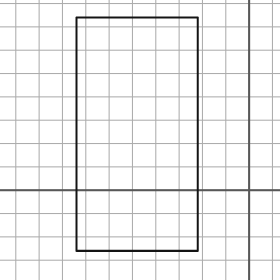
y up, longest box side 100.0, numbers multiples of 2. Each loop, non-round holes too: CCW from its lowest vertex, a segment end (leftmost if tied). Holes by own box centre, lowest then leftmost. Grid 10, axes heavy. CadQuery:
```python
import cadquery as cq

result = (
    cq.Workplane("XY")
    .moveTo(-74.0, -26.0)
    .lineTo(-22.0, -26.0)
    .lineTo(-22.0, 74.0)
    .lineTo(-74.0, 74.0)
    .close()
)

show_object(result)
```